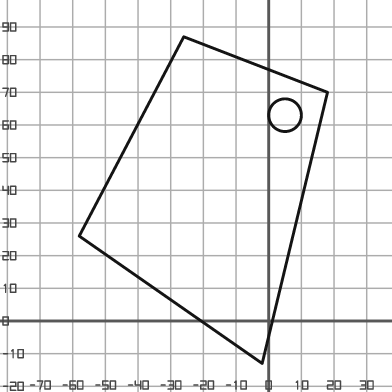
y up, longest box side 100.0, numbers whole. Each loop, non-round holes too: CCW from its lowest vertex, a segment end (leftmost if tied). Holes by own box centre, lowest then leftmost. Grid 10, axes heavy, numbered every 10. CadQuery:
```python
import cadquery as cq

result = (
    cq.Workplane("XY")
    .moveTo(-2.0, -13.0)
    .lineTo(18.0, 70.0)
    .lineTo(-26.0, 87.0)
    .lineTo(-58.0, 26.0)
    .close()
    .moveTo(5.0, 63.0)
    .circle(5.0)
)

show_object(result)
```